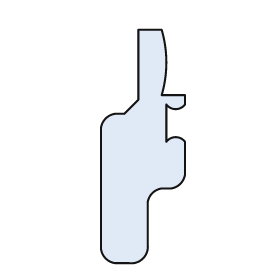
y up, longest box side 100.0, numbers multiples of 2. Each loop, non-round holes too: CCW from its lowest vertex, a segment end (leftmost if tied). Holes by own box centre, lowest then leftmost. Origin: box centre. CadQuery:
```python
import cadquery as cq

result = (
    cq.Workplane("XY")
    .moveTo(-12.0, -50.0)
    .lineTo(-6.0, -50.0)
    .threePointArc((0.0, -48.0), (2.0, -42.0))
    .lineTo(2.0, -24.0)
    .threePointArc((4.0, -20.0), (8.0, -18.0))
    .lineTo(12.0, -18.0)
    .threePointArc((16.0, -16.0), (18.0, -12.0))
    .lineTo(18.0, 2.0)
    .threePointArc((14.0, 4.0), (10.0, 2.0))
    .lineTo(10.0, 18.0)
    .threePointArc((14.0, 16.0), (18.0, 18.0))
    .lineTo(18.0, 22.0)
    .lineTo(8.0, 22.0)
    .threePointArc((10.0, 36.0), (8.0, 50.0))
    .lineTo(-2.0, 50.0)
    .lineTo(-2.0, 20.0)
    .lineTo(-8.0, 14.0)
    .lineTo(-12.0, 14.0)
    .threePointArc((-16.0, 12.0), (-18.0, 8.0))
    .lineTo(-18.0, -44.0)
    .threePointArc((-16.0, -48.0), (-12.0, -50.0))
    .close()
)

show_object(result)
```